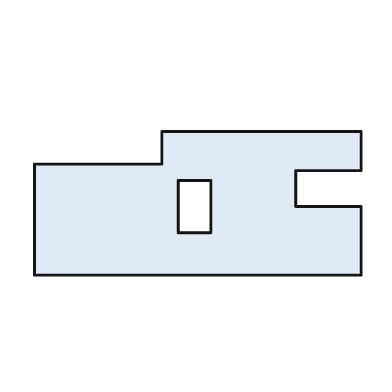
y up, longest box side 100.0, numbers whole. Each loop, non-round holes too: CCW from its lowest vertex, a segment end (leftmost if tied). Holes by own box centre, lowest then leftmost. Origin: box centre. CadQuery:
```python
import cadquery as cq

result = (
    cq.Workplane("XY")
    .moveTo(-50.0, -22.0)
    .lineTo(50.0, -22.0)
    .lineTo(50.0, -1.0)
    .lineTo(30.0, -1.0)
    .lineTo(30.0, 10.0)
    .lineTo(50.0, 10.0)
    .lineTo(50.0, 22.0)
    .lineTo(-11.0, 22.0)
    .lineTo(-11.0, 12.0)
    .lineTo(-50.0, 12.0)
    .close()
    .moveTo(-6.0, -9.0)
    .lineTo(4.0, -9.0)
    .lineTo(4.0, 7.0)
    .lineTo(-6.0, 7.0)
    .close()
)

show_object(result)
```